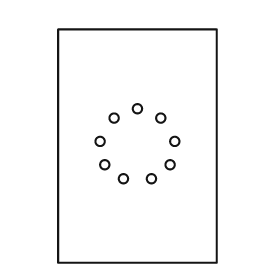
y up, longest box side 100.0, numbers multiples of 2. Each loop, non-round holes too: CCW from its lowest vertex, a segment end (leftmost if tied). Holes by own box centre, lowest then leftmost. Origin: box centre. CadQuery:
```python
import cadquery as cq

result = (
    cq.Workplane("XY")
    .moveTo(-34.0, -50.0)
    .lineTo(34.0, -50.0)
    .lineTo(34.0, 50.0)
    .lineTo(-34.0, 50.0)
    .close()
    .moveTo(-6.0, -14.0)
    .circle(2.0)
    .moveTo(6.0, -14.0)
    .circle(2.0)
    .moveTo(-14.0, -8.0)
    .circle(2.0)
    .moveTo(14.0, -8.0)
    .circle(2.0)
    .moveTo(-16.0, 2.0)
    .circle(2.0)
    .moveTo(16.0, 2.0)
    .circle(2.0)
    .moveTo(-10.0, 12.0)
    .circle(2.0)
    .moveTo(10.0, 12.0)
    .circle(2.0)
    .moveTo(0.0, 16.0)
    .circle(2.0)
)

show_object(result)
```